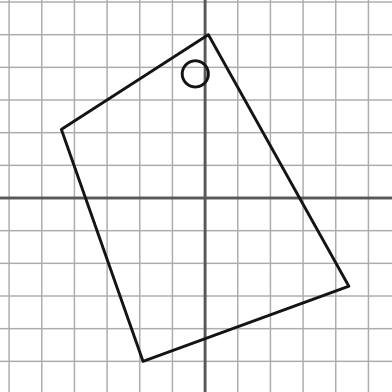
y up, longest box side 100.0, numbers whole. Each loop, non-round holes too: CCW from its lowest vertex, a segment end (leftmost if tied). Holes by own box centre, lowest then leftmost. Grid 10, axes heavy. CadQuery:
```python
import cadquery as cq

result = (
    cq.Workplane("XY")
    .moveTo(-19.0, -50.0)
    .lineTo(44.0, -27.0)
    .lineTo(1.0, 50.0)
    .lineTo(-44.0, 21.0)
    .close()
    .moveTo(-3.0, 38.0)
    .circle(4.0)
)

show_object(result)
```